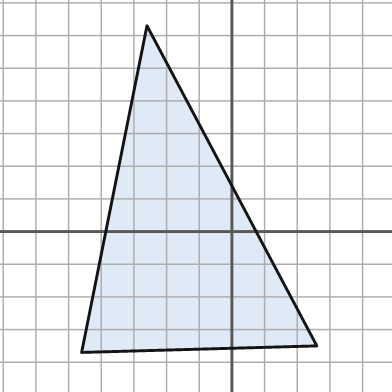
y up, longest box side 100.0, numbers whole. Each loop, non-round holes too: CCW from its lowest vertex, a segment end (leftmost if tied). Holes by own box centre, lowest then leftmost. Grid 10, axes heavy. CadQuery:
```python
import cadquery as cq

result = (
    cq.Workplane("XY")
    .moveTo(-46.0, -37.0)
    .lineTo(26.0, -35.0)
    .lineTo(-26.0, 63.0)
    .close()
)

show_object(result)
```